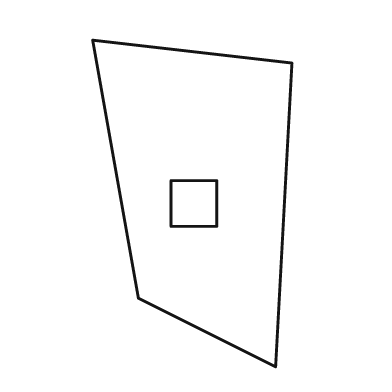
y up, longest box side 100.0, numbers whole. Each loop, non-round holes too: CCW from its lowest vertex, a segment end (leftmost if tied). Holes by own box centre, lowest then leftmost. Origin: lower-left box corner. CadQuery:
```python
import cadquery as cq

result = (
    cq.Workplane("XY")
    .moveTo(56.0, 0.0)
    .lineTo(61.0, 93.0)
    .lineTo(0.0, 100.0)
    .lineTo(14.0, 21.0)
    .close()
    .moveTo(24.0, 43.0)
    .lineTo(38.0, 43.0)
    .lineTo(38.0, 57.0)
    .lineTo(24.0, 57.0)
    .close()
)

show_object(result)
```